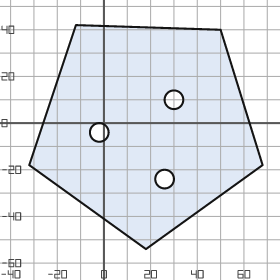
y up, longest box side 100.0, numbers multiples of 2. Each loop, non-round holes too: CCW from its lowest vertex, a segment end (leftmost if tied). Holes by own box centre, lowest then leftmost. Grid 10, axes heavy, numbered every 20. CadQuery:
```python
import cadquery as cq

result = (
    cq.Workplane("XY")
    .moveTo(18.0, -54.0)
    .lineTo(68.0, -18.0)
    .lineTo(50.0, 40.0)
    .lineTo(-12.0, 42.0)
    .lineTo(-32.0, -18.0)
    .close()
    .moveTo(26.0, -24.0)
    .circle(4.0)
    .moveTo(-2.0, -4.0)
    .circle(4.0)
    .moveTo(30.0, 10.0)
    .circle(4.0)
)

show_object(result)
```